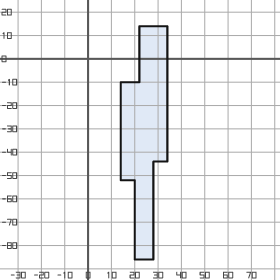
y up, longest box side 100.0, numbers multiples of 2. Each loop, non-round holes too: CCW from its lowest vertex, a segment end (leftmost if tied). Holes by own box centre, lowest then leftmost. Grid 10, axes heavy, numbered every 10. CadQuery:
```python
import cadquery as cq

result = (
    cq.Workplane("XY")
    .moveTo(20.0, -86.0)
    .lineTo(28.0, -86.0)
    .lineTo(28.0, -44.0)
    .lineTo(34.0, -44.0)
    .lineTo(34.0, 14.0)
    .lineTo(22.0, 14.0)
    .lineTo(22.0, -10.0)
    .lineTo(14.0, -10.0)
    .lineTo(14.0, -52.0)
    .lineTo(20.0, -52.0)
    .close()
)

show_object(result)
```